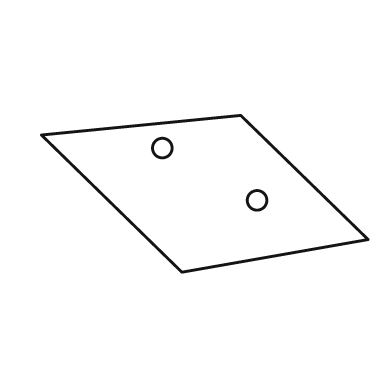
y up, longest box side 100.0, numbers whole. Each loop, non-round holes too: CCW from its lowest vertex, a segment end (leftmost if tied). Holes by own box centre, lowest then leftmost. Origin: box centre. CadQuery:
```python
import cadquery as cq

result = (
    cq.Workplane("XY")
    .moveTo(-7.0, -24.0)
    .lineTo(50.0, -14.0)
    .lineTo(11.0, 24.0)
    .lineTo(-50.0, 18.0)
    .close()
    .moveTo(16.0, -2.0)
    .circle(3.0)
    .moveTo(-13.0, 14.0)
    .circle(3.0)
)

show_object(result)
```